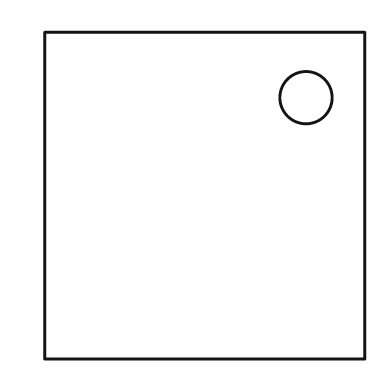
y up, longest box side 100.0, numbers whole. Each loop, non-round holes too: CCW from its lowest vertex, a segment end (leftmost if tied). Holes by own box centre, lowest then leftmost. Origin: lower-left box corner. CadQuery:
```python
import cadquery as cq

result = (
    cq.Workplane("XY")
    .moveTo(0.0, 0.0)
    .lineTo(98.0, 0.0)
    .lineTo(98.0, 100.0)
    .lineTo(0.0, 100.0)
    .close()
    .moveTo(80.0, 80.0)
    .circle(8.0)
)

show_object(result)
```